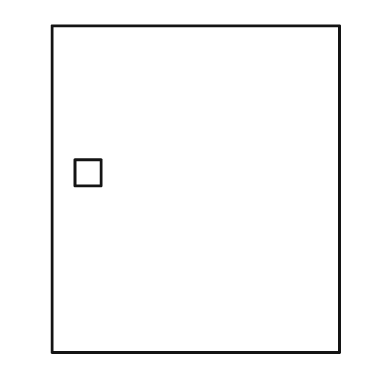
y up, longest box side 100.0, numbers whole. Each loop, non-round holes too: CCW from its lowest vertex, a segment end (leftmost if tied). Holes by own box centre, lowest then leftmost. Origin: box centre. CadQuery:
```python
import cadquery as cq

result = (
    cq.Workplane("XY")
    .moveTo(-44.0, -50.0)
    .lineTo(44.0, -50.0)
    .lineTo(44.0, 50.0)
    .lineTo(-44.0, 50.0)
    .close()
    .moveTo(-37.0, 1.0)
    .lineTo(-29.0, 1.0)
    .lineTo(-29.0, 9.0)
    .lineTo(-37.0, 9.0)
    .close()
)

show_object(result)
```